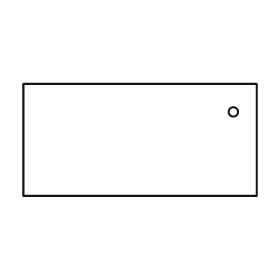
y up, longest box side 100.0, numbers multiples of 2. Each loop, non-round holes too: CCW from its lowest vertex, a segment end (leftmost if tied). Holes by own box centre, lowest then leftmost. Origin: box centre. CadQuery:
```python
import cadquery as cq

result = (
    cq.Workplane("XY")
    .moveTo(-50.0, -24.0)
    .lineTo(50.0, -24.0)
    .lineTo(50.0, 24.0)
    .lineTo(-50.0, 24.0)
    .close()
    .moveTo(40.0, 12.0)
    .circle(2.0)
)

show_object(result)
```